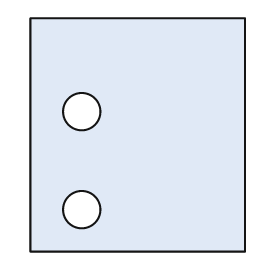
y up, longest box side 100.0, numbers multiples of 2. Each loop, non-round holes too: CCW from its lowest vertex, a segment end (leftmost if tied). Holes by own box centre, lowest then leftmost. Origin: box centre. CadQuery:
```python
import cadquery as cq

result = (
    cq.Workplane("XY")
    .moveTo(-46.0, -50.0)
    .lineTo(46.0, -50.0)
    .lineTo(46.0, 50.0)
    .lineTo(-46.0, 50.0)
    .close()
    .moveTo(-24.0, -32.0)
    .circle(8.0)
    .moveTo(-24.0, 10.0)
    .circle(8.0)
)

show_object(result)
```